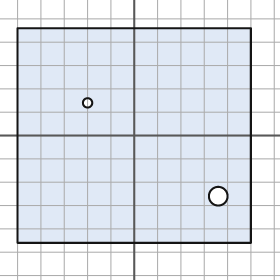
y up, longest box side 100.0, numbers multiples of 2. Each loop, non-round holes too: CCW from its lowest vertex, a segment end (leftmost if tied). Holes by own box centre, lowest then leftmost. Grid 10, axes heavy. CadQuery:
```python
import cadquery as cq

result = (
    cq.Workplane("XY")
    .moveTo(-50.0, -46.0)
    .lineTo(50.0, -46.0)
    .lineTo(50.0, 46.0)
    .lineTo(-50.0, 46.0)
    .close()
    .moveTo(36.0, -26.0)
    .circle(4.0)
    .moveTo(-20.0, 14.0)
    .circle(2.0)
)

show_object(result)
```